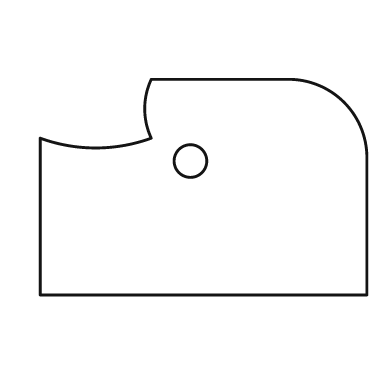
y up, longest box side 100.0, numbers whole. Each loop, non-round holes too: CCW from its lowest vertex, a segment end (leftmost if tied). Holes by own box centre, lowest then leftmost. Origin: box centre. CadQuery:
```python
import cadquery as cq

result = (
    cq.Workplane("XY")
    .moveTo(-50.0, -33.0)
    .lineTo(50.0, -33.0)
    .lineTo(50.0, 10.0)
    .threePointArc((43.0, 26.0), (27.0, 33.0))
    .lineTo(-16.0, 33.0)
    .threePointArc((-18.0, 24.0), (-16.0, 15.0))
    .threePointArc((-33.0, 12.0), (-50.0, 15.0))
    .close()
    .moveTo(-4.0, 8.0)
    .circle(5.0)
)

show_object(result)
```